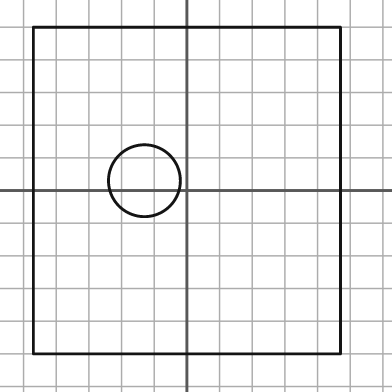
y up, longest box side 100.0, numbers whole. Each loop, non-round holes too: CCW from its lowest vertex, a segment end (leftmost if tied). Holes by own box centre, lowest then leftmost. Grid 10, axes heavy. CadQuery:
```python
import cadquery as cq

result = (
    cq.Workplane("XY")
    .moveTo(-47.0, -50.0)
    .lineTo(47.0, -50.0)
    .lineTo(47.0, 50.0)
    .lineTo(-47.0, 50.0)
    .close()
    .moveTo(-13.0, 3.0)
    .circle(11.0)
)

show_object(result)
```